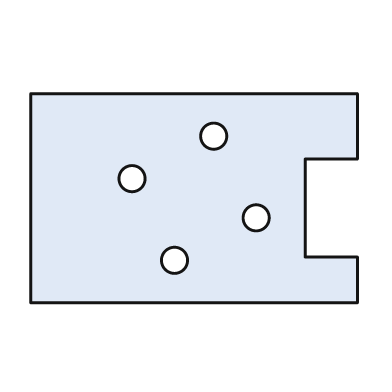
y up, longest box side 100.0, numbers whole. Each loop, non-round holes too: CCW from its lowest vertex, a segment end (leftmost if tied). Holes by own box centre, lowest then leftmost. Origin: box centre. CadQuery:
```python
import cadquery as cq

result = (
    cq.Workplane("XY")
    .moveTo(-50.0, -32.0)
    .lineTo(50.0, -32.0)
    .lineTo(50.0, -18.0)
    .lineTo(34.0, -18.0)
    .lineTo(34.0, 12.0)
    .lineTo(50.0, 12.0)
    .lineTo(50.0, 32.0)
    .lineTo(-50.0, 32.0)
    .close()
    .moveTo(-6.0, -19.0)
    .circle(4.0)
    .moveTo(19.0, -6.0)
    .circle(4.0)
    .moveTo(-19.0, 6.0)
    .circle(4.0)
    .moveTo(6.0, 19.0)
    .circle(4.0)
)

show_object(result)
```